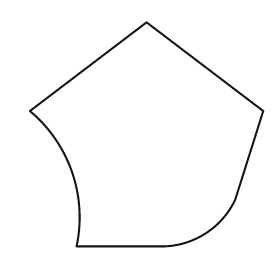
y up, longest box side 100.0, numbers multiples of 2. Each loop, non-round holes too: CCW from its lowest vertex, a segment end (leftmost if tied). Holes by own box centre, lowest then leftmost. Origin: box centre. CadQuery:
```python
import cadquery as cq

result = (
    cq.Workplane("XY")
    .moveTo(-30.0, -48.0)
    .lineTo(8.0, -48.0)
    .threePointArc((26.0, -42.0), (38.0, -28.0))
    .lineTo(50.0, 10.0)
    .lineTo(0.0, 48.0)
    .lineTo(-50.0, 10.0)
    .threePointArc((-32.0, -16.0), (-30.0, -48.0))
    .close()
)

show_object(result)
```